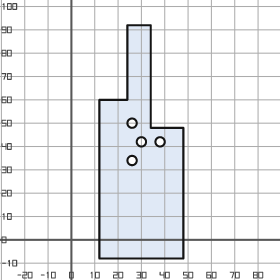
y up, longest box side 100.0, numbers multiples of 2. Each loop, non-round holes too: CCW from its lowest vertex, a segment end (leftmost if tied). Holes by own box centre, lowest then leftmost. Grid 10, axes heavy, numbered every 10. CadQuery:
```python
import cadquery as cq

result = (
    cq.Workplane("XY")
    .moveTo(12.0, -8.0)
    .lineTo(48.0, -8.0)
    .lineTo(48.0, 48.0)
    .lineTo(34.0, 48.0)
    .lineTo(34.0, 92.0)
    .lineTo(24.0, 92.0)
    .lineTo(24.0, 60.0)
    .lineTo(12.0, 60.0)
    .close()
    .moveTo(26.0, 34.0)
    .circle(2.0)
    .moveTo(30.0, 42.0)
    .circle(2.0)
    .moveTo(38.0, 42.0)
    .circle(2.0)
    .moveTo(26.0, 50.0)
    .circle(2.0)
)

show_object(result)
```